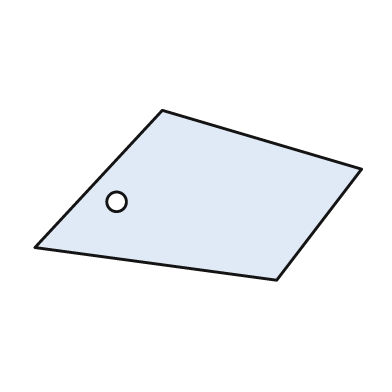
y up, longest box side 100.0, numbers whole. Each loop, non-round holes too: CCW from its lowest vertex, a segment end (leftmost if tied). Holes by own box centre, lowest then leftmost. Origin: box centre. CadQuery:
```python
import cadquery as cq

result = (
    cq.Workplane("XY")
    .moveTo(24.0, -26.0)
    .lineTo(50.0, 8.0)
    .lineTo(-11.0, 26.0)
    .lineTo(-50.0, -16.0)
    .close()
    .moveTo(-25.0, -2.0)
    .circle(3.0)
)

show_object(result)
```